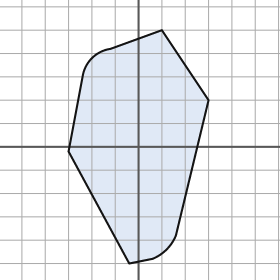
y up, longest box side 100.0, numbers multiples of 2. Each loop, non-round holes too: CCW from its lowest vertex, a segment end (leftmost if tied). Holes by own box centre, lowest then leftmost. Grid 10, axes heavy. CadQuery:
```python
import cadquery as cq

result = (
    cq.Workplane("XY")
    .moveTo(-4.0, -50.0)
    .lineTo(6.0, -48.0)
    .threePointArc((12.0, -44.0), (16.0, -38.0))
    .lineTo(30.0, 20.0)
    .lineTo(10.0, 50.0)
    .lineTo(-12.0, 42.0)
    .threePointArc((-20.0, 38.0), (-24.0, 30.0))
    .lineTo(-30.0, -2.0)
    .close()
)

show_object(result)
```